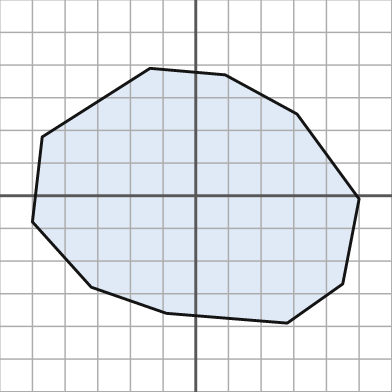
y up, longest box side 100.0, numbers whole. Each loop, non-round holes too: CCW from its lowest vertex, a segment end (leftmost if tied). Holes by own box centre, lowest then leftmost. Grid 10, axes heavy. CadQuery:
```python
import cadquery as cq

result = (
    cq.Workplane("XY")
    .moveTo(28.0, -39.0)
    .lineTo(45.0, -27.0)
    .lineTo(50.0, -1.0)
    .lineTo(31.0, 25.0)
    .lineTo(9.0, 37.0)
    .lineTo(-14.0, 39.0)
    .lineTo(-47.0, 18.0)
    .lineTo(-50.0, -8.0)
    .lineTo(-32.0, -28.0)
    .lineTo(-9.0, -36.0)
    .close()
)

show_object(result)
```